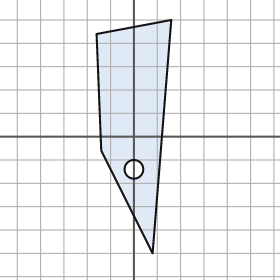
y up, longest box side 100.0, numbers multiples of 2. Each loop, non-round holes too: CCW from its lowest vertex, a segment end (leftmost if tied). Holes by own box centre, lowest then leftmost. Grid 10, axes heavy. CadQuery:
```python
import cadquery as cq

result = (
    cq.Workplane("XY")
    .moveTo(8.0, -50.0)
    .lineTo(16.0, 50.0)
    .lineTo(-16.0, 44.0)
    .lineTo(-14.0, -6.0)
    .close()
    .moveTo(0.0, -14.0)
    .circle(4.0)
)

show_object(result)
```